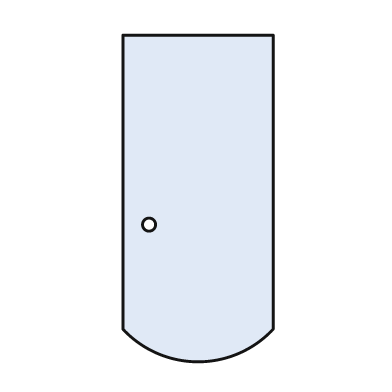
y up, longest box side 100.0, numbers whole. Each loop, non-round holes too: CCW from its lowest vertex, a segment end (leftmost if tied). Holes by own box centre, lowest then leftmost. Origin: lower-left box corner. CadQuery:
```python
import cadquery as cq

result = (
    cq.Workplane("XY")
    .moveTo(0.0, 10.0)
    .threePointArc((23.0, 0.0), (46.0, 10.0))
    .lineTo(46.0, 100.0)
    .lineTo(0.0, 100.0)
    .close()
    .moveTo(8.0, 42.0)
    .circle(2.0)
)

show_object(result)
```